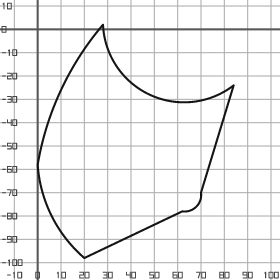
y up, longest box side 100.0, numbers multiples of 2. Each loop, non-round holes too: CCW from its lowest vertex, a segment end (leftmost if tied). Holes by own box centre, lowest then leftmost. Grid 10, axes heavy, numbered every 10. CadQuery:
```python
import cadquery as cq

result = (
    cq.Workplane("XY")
    .moveTo(20.0, -98.0)
    .lineTo(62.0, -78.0)
    .threePointArc((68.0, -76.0), (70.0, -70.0))
    .lineTo(84.0, -24.0)
    .threePointArc((48.0, -28.0), (28.0, 2.0))
    .threePointArc((10.0, -26.0), (0.0, -58.0))
    .threePointArc((6.0, -80.0), (20.0, -98.0))
    .close()
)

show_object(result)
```